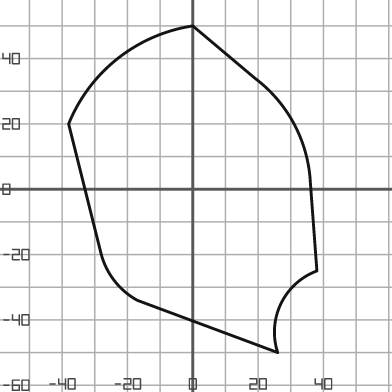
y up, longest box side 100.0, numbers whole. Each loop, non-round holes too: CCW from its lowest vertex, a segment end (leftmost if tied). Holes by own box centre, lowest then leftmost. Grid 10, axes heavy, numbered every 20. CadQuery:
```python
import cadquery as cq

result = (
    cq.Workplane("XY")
    .moveTo(26.0, -50.0)
    .threePointArc((27.0, -35.0), (38.0, -25.0))
    .lineTo(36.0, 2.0)
    .threePointArc((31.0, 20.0), (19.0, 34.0))
    .lineTo(0.0, 50.0)
    .threePointArc((-23.0, 40.0), (-38.0, 20.0))
    .lineTo(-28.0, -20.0)
    .threePointArc((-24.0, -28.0), (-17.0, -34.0))
    .close()
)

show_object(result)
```